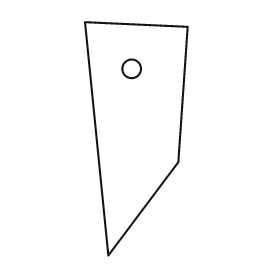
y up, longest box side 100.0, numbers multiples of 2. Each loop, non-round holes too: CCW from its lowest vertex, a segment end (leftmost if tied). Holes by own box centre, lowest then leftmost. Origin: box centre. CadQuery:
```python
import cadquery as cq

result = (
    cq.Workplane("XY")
    .moveTo(-12.0, -50.0)
    .lineTo(18.0, -10.0)
    .lineTo(22.0, 48.0)
    .lineTo(-22.0, 50.0)
    .close()
    .moveTo(-2.0, 30.0)
    .circle(4.0)
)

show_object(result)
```